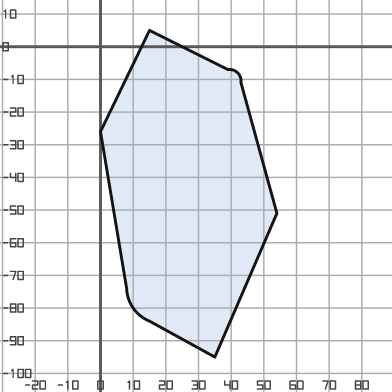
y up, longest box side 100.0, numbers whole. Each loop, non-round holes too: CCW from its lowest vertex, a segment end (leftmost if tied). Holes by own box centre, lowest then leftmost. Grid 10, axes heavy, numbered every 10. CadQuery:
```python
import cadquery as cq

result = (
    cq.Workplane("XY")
    .moveTo(35.0, -95.0)
    .lineTo(54.0, -51.0)
    .lineTo(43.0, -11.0)
    .threePointArc((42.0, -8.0), (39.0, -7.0))
    .lineTo(15.0, 5.0)
    .lineTo(0.0, -26.0)
    .lineTo(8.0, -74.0)
    .threePointArc((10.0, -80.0), (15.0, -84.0))
    .close()
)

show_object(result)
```